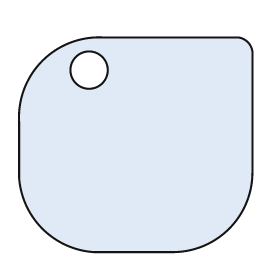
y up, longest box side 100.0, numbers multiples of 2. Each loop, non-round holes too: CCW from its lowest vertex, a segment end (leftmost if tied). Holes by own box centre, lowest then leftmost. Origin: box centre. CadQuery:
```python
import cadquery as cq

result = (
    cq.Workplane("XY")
    .moveTo(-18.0, -46.0)
    .lineTo(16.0, -46.0)
    .threePointArc((40.0, -36.0), (50.0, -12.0))
    .lineTo(50.0, 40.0)
    .threePointArc((48.0, 44.0), (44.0, 46.0))
    .lineTo(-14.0, 46.0)
    .threePointArc((-40.0, 36.0), (-50.0, 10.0))
    .lineTo(-50.0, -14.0)
    .threePointArc((-40.0, -36.0), (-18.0, -46.0))
    .close()
    .moveTo(-20.0, 32.0)
    .circle(8.0)
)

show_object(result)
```